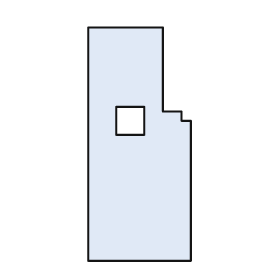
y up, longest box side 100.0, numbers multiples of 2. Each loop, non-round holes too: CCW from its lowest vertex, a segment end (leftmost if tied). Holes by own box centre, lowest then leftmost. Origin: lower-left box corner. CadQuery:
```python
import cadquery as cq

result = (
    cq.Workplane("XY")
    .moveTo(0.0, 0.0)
    .lineTo(44.0, 0.0)
    .lineTo(44.0, 60.0)
    .lineTo(40.0, 60.0)
    .lineTo(40.0, 64.0)
    .lineTo(32.0, 64.0)
    .lineTo(32.0, 100.0)
    .lineTo(0.0, 100.0)
    .close()
    .moveTo(12.0, 54.0)
    .lineTo(24.0, 54.0)
    .lineTo(24.0, 66.0)
    .lineTo(12.0, 66.0)
    .close()
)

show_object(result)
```